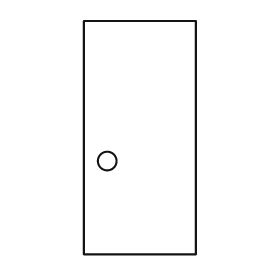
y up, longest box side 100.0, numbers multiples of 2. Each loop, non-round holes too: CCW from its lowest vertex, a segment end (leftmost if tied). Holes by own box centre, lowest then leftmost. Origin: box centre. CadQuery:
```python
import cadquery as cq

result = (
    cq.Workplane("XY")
    .moveTo(-24.0, -50.0)
    .lineTo(24.0, -50.0)
    .lineTo(24.0, 50.0)
    .lineTo(-24.0, 50.0)
    .close()
    .moveTo(-14.0, -10.0)
    .circle(4.0)
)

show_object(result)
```